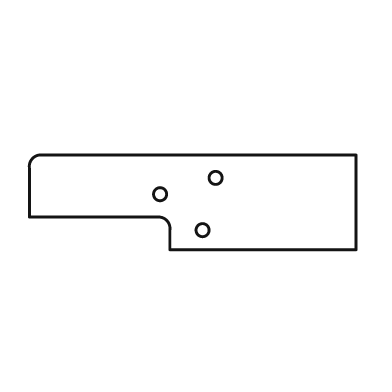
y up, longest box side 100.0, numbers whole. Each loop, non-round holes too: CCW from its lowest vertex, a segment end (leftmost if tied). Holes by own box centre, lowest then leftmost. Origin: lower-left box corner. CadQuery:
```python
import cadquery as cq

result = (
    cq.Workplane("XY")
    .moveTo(43.0, 0.0)
    .lineTo(100.0, 0.0)
    .lineTo(100.0, 29.0)
    .lineTo(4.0, 29.0)
    .threePointArc((1.0, 28.0), (0.0, 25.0))
    .lineTo(0.0, 10.0)
    .lineTo(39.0, 10.0)
    .threePointArc((42.0, 9.0), (43.0, 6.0))
    .close()
    .moveTo(53.0, 6.0)
    .circle(2.0)
    .moveTo(40.0, 17.0)
    .circle(2.0)
    .moveTo(57.0, 22.0)
    .circle(2.0)
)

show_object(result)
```